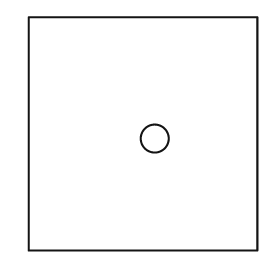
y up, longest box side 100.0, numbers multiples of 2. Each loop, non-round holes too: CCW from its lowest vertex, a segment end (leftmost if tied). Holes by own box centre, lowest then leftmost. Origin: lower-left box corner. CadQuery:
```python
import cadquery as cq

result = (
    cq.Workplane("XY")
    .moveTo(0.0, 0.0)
    .lineTo(98.0, 0.0)
    .lineTo(98.0, 100.0)
    .lineTo(0.0, 100.0)
    .close()
    .moveTo(54.0, 48.0)
    .circle(6.0)
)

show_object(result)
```